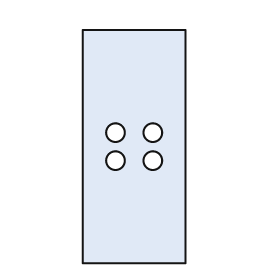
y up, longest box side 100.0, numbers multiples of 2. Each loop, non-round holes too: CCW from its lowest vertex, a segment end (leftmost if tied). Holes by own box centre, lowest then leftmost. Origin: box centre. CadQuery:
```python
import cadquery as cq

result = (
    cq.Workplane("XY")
    .moveTo(-22.0, -50.0)
    .lineTo(22.0, -50.0)
    .lineTo(22.0, 50.0)
    .lineTo(-22.0, 50.0)
    .close()
    .moveTo(-8.0, -6.0)
    .circle(4.0)
    .moveTo(8.0, -6.0)
    .circle(4.0)
    .moveTo(-8.0, 6.0)
    .circle(4.0)
    .moveTo(8.0, 6.0)
    .circle(4.0)
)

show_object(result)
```